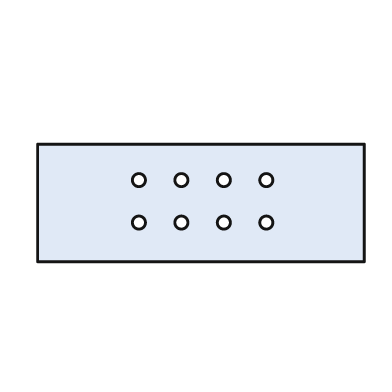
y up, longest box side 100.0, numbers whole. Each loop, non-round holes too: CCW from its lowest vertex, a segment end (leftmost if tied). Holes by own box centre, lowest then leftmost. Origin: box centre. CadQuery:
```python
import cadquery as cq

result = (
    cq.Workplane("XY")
    .moveTo(-50.0, -18.0)
    .lineTo(50.0, -18.0)
    .lineTo(50.0, 18.0)
    .lineTo(-50.0, 18.0)
    .close()
    .moveTo(-19.0, -6.0)
    .circle(2.0)
    .moveTo(-6.0, -6.0)
    .circle(2.0)
    .moveTo(7.0, -6.0)
    .circle(2.0)
    .moveTo(20.0, -6.0)
    .circle(2.0)
    .moveTo(-19.0, 7.0)
    .circle(2.0)
    .moveTo(-6.0, 7.0)
    .circle(2.0)
    .moveTo(7.0, 7.0)
    .circle(2.0)
    .moveTo(20.0, 7.0)
    .circle(2.0)
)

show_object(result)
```